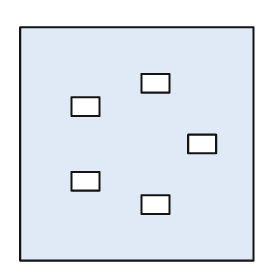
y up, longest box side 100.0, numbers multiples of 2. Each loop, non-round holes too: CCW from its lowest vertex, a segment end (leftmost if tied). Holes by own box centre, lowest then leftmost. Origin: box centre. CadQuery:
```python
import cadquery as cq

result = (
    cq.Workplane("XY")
    .moveTo(-50.0, -50.0)
    .lineTo(50.0, -50.0)
    .lineTo(50.0, 50.0)
    .lineTo(-50.0, 50.0)
    .close()
    .moveTo(2.0, -30.0)
    .lineTo(14.0, -30.0)
    .lineTo(14.0, -22.0)
    .lineTo(2.0, -22.0)
    .close()
    .moveTo(-28.0, -20.0)
    .lineTo(-16.0, -20.0)
    .lineTo(-16.0, -12.0)
    .lineTo(-28.0, -12.0)
    .close()
    .moveTo(22.0, -4.0)
    .lineTo(34.0, -4.0)
    .lineTo(34.0, 4.0)
    .lineTo(22.0, 4.0)
    .close()
    .moveTo(-28.0, 12.0)
    .lineTo(-16.0, 12.0)
    .lineTo(-16.0, 20.0)
    .lineTo(-28.0, 20.0)
    .close()
    .moveTo(2.0, 22.0)
    .lineTo(14.0, 22.0)
    .lineTo(14.0, 30.0)
    .lineTo(2.0, 30.0)
    .close()
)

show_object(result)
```